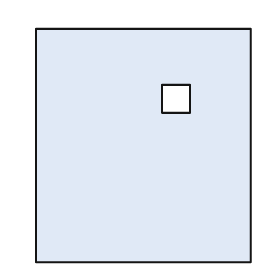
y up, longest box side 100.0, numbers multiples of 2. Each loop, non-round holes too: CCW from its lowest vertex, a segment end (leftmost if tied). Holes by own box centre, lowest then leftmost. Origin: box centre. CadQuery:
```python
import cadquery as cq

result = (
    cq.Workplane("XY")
    .moveTo(-46.0, -50.0)
    .lineTo(46.0, -50.0)
    .lineTo(46.0, 50.0)
    .lineTo(-46.0, 50.0)
    .close()
    .moveTo(8.0, 14.0)
    .lineTo(20.0, 14.0)
    .lineTo(20.0, 26.0)
    .lineTo(8.0, 26.0)
    .close()
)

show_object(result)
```